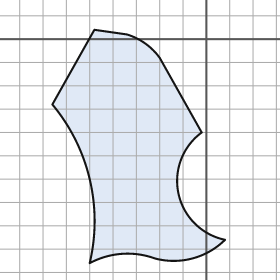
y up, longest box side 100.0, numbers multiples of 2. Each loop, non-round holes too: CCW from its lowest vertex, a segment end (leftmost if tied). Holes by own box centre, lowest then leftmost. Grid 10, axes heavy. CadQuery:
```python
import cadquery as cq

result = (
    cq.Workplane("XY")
    .moveTo(-50.0, -96.0)
    .threePointArc((-36.0, -92.0), (-22.0, -94.0))
    .threePointArc((-6.0, -94.0), (8.0, -86.0))
    .threePointArc((-12.0, -66.0), (-2.0, -40.0))
    .lineTo(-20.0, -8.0)
    .threePointArc((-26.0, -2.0), (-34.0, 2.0))
    .lineTo(-48.0, 4.0)
    .lineTo(-66.0, -28.0)
    .threePointArc((-50.0, -60.0), (-50.0, -96.0))
    .close()
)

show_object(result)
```